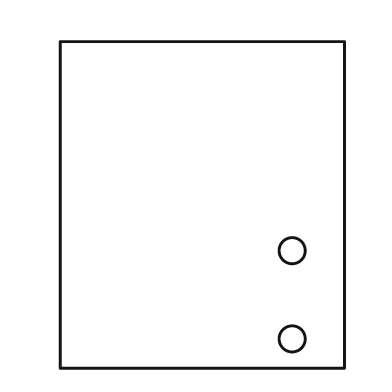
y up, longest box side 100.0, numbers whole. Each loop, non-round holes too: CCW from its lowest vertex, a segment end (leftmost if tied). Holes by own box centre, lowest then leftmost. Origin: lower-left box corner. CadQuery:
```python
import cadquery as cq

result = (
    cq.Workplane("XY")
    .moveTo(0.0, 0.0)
    .lineTo(87.0, 0.0)
    .lineTo(87.0, 100.0)
    .lineTo(0.0, 100.0)
    .close()
    .moveTo(71.0, 9.0)
    .circle(4.0)
    .moveTo(71.0, 36.0)
    .circle(4.0)
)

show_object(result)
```